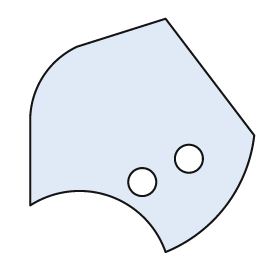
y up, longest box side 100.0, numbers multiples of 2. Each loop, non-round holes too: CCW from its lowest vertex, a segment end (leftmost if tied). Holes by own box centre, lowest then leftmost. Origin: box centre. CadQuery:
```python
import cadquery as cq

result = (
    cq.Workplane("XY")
    .moveTo(10.0, -50.0)
    .threePointArc((36.0, -30.0), (48.0, 0.0))
    .lineTo(10.0, 50.0)
    .lineTo(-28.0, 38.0)
    .threePointArc((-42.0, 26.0), (-48.0, 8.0))
    .lineTo(-48.0, -30.0)
    .threePointArc((-14.0, -26.0), (10.0, -50.0))
    .close()
    .moveTo(0.0, -20.0)
    .circle(6.0)
    .moveTo(20.0, -10.0)
    .circle(6.0)
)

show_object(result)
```